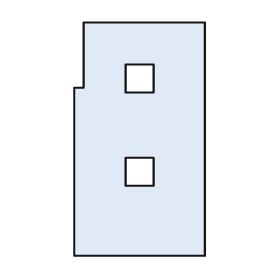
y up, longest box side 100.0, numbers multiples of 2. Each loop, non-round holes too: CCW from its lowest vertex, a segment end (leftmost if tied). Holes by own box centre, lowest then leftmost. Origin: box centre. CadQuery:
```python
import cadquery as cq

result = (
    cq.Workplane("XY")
    .moveTo(-28.0, -50.0)
    .lineTo(28.0, -50.0)
    .lineTo(28.0, 50.0)
    .lineTo(-24.0, 50.0)
    .lineTo(-24.0, 22.0)
    .lineTo(-28.0, 22.0)
    .close()
    .moveTo(-6.0, -20.0)
    .lineTo(6.0, -20.0)
    .lineTo(6.0, -8.0)
    .lineTo(-6.0, -8.0)
    .close()
    .moveTo(-6.0, 20.0)
    .lineTo(6.0, 20.0)
    .lineTo(6.0, 32.0)
    .lineTo(-6.0, 32.0)
    .close()
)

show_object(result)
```